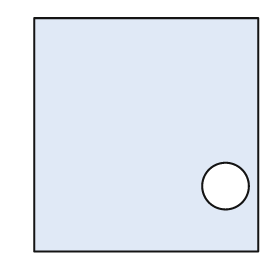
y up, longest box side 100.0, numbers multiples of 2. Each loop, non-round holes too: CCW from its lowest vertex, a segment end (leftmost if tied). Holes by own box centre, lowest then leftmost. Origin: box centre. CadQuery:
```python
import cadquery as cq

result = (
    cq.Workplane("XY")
    .moveTo(-48.0, -50.0)
    .lineTo(48.0, -50.0)
    .lineTo(48.0, 50.0)
    .lineTo(-48.0, 50.0)
    .close()
    .moveTo(34.0, -22.0)
    .circle(10.0)
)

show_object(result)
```